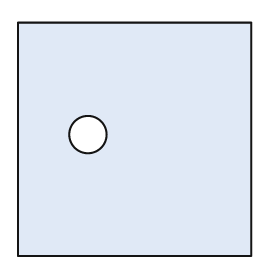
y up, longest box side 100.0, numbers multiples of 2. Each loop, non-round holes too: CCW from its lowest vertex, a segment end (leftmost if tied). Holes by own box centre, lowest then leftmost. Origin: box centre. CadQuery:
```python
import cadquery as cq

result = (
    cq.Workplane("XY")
    .moveTo(-50.0, -50.0)
    .lineTo(50.0, -50.0)
    .lineTo(50.0, 50.0)
    .lineTo(-50.0, 50.0)
    .close()
    .moveTo(-20.0, 2.0)
    .circle(8.0)
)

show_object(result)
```